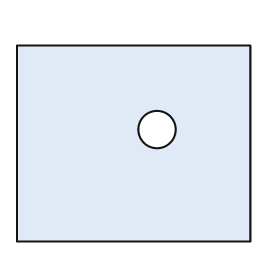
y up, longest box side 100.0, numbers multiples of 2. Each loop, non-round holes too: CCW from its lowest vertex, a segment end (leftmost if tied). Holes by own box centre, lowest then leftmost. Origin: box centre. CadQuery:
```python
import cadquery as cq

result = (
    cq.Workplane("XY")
    .moveTo(-50.0, -42.0)
    .lineTo(50.0, -42.0)
    .lineTo(50.0, 42.0)
    .lineTo(-50.0, 42.0)
    .close()
    .moveTo(10.0, 6.0)
    .circle(8.0)
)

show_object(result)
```